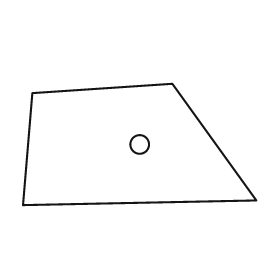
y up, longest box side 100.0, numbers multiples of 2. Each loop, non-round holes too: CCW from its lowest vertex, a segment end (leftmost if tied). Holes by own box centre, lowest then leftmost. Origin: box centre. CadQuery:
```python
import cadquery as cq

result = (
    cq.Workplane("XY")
    .moveTo(-50.0, -26.0)
    .lineTo(50.0, -24.0)
    .lineTo(14.0, 26.0)
    .lineTo(-46.0, 22.0)
    .close()
    .moveTo(0.0, 0.0)
    .circle(4.0)
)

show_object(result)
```